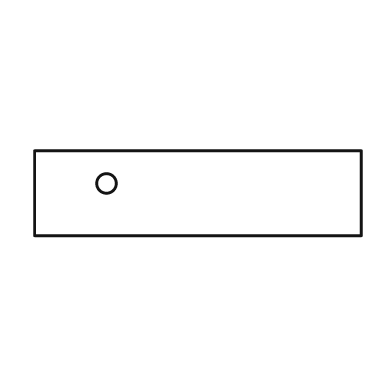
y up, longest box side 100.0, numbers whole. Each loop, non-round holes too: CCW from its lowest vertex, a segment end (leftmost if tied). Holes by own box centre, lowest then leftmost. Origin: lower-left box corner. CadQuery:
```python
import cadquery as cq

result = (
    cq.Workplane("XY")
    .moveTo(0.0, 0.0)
    .lineTo(100.0, 0.0)
    .lineTo(100.0, 26.0)
    .lineTo(0.0, 26.0)
    .close()
    .moveTo(22.0, 16.0)
    .circle(3.0)
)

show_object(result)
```